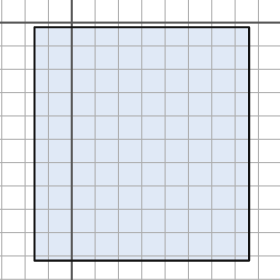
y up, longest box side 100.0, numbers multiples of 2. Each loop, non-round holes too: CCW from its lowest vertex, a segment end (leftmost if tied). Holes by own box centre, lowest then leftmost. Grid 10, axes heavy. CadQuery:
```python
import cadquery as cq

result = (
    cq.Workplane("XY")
    .moveTo(-16.0, -102.0)
    .lineTo(76.0, -102.0)
    .lineTo(76.0, -2.0)
    .lineTo(-16.0, -2.0)
    .close()
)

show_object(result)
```